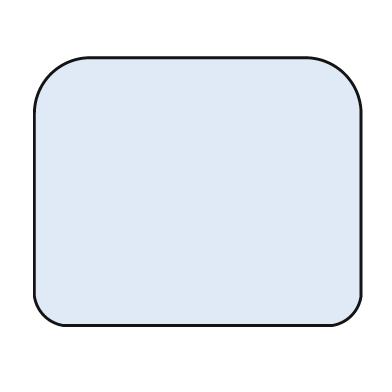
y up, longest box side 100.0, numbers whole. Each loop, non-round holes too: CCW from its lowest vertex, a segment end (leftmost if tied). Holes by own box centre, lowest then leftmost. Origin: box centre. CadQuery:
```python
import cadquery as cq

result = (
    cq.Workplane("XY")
    .moveTo(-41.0, -41.0)
    .lineTo(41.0, -41.0)
    .threePointArc((47.0, -38.0), (50.0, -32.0))
    .lineTo(50.0, 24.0)
    .threePointArc((45.0, 36.0), (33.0, 41.0))
    .lineTo(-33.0, 41.0)
    .threePointArc((-45.0, 36.0), (-50.0, 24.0))
    .lineTo(-50.0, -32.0)
    .threePointArc((-47.0, -38.0), (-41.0, -41.0))
    .close()
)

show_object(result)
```